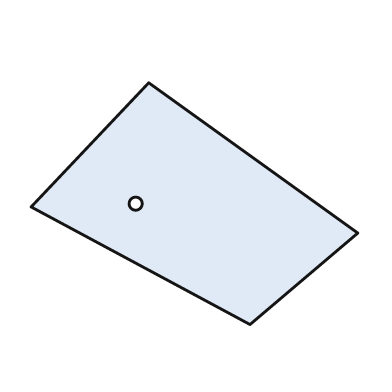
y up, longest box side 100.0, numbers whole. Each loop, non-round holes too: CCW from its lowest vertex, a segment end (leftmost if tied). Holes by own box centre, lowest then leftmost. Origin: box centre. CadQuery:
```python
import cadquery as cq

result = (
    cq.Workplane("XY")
    .moveTo(17.0, -37.0)
    .lineTo(50.0, -9.0)
    .lineTo(-14.0, 37.0)
    .lineTo(-50.0, -1.0)
    .close()
    .moveTo(-18.0, 0.0)
    .circle(2.0)
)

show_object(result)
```